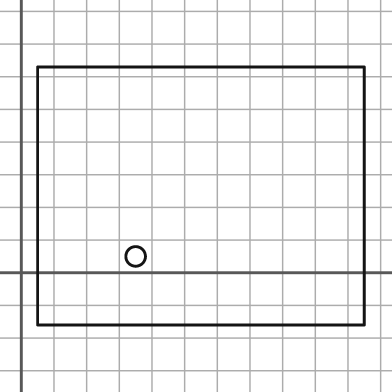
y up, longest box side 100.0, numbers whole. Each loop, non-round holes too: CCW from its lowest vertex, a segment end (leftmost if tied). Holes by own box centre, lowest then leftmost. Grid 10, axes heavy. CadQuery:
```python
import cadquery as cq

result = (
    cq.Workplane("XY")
    .moveTo(5.0, -16.0)
    .lineTo(105.0, -16.0)
    .lineTo(105.0, 63.0)
    .lineTo(5.0, 63.0)
    .close()
    .moveTo(35.0, 5.0)
    .circle(3.0)
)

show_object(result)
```